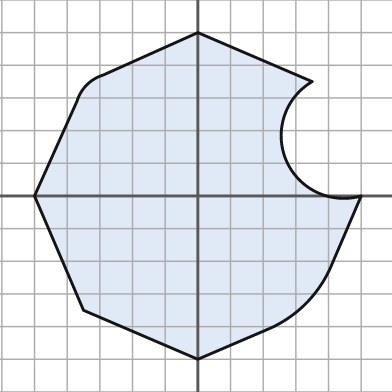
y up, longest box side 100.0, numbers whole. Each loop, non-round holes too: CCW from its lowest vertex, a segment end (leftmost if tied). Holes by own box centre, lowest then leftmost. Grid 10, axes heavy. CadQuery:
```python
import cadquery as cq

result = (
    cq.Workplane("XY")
    .moveTo(0.0, -50.0)
    .lineTo(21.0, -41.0)
    .threePointArc((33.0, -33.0), (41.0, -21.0))
    .lineTo(50.0, 0.0)
    .threePointArc((27.0, 11.0), (35.0, 35.0))
    .lineTo(0.0, 50.0)
    .lineTo(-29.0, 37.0)
    .threePointArc((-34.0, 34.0), (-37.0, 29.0))
    .lineTo(-50.0, 0.0)
    .lineTo(-35.0, -35.0)
    .close()
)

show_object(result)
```